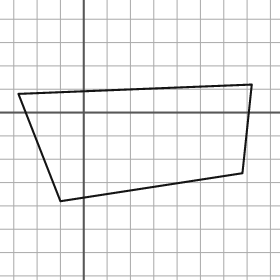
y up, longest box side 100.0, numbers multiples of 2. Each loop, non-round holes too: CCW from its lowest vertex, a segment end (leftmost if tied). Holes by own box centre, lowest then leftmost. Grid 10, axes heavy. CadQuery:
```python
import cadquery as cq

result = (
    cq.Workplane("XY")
    .moveTo(-10.0, -38.0)
    .lineTo(68.0, -26.0)
    .lineTo(72.0, 12.0)
    .lineTo(-28.0, 8.0)
    .close()
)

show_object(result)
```